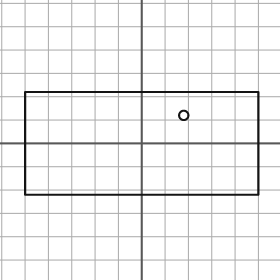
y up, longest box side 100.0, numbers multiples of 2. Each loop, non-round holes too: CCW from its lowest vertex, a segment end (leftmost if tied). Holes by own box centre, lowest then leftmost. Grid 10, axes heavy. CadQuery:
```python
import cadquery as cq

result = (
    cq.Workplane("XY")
    .moveTo(-50.0, -22.0)
    .lineTo(50.0, -22.0)
    .lineTo(50.0, 22.0)
    .lineTo(-50.0, 22.0)
    .close()
    .moveTo(18.0, 12.0)
    .circle(2.0)
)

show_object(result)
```